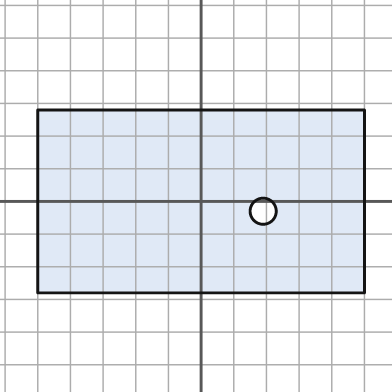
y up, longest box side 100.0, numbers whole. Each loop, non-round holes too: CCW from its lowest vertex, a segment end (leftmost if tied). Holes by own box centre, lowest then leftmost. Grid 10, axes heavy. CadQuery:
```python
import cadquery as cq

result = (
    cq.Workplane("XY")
    .moveTo(-50.0, -28.0)
    .lineTo(50.0, -28.0)
    .lineTo(50.0, 28.0)
    .lineTo(-50.0, 28.0)
    .close()
    .moveTo(19.0, -3.0)
    .circle(4.0)
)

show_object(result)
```